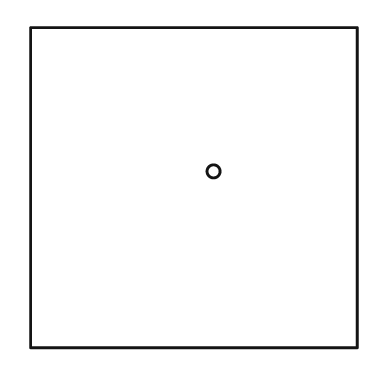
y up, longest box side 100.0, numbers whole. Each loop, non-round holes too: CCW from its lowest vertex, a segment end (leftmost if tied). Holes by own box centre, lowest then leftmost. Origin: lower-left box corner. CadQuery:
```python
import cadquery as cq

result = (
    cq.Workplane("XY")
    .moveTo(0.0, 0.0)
    .lineTo(100.0, 0.0)
    .lineTo(100.0, 98.0)
    .lineTo(0.0, 98.0)
    .close()
    .moveTo(56.0, 54.0)
    .circle(2.0)
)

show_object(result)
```